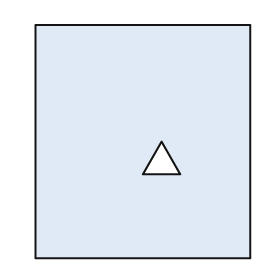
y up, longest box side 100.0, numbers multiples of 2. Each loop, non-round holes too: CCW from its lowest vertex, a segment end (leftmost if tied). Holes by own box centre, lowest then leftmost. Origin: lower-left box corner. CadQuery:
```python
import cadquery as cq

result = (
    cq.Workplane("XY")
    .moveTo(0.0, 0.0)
    .lineTo(92.0, 0.0)
    .lineTo(92.0, 100.0)
    .lineTo(0.0, 100.0)
    .close()
    .moveTo(46.0, 36.0)
    .lineTo(62.0, 36.0)
    .lineTo(54.0, 50.0)
    .close()
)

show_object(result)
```